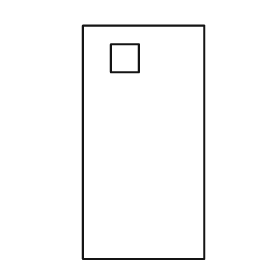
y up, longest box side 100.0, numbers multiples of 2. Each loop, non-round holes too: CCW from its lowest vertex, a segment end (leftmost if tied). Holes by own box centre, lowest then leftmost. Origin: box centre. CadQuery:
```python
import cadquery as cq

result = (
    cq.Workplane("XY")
    .moveTo(-26.0, -50.0)
    .lineTo(26.0, -50.0)
    .lineTo(26.0, 50.0)
    .lineTo(-26.0, 50.0)
    .close()
    .moveTo(-14.0, 30.0)
    .lineTo(-2.0, 30.0)
    .lineTo(-2.0, 42.0)
    .lineTo(-14.0, 42.0)
    .close()
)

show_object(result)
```